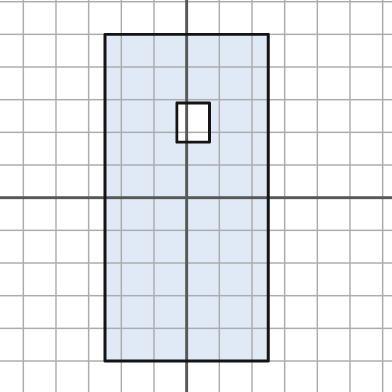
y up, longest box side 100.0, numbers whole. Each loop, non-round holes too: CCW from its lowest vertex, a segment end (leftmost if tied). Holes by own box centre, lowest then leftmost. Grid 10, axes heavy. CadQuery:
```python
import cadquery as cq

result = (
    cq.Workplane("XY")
    .moveTo(-25.0, -50.0)
    .lineTo(25.0, -50.0)
    .lineTo(25.0, 50.0)
    .lineTo(-25.0, 50.0)
    .close()
    .moveTo(-3.0, 17.0)
    .lineTo(7.0, 17.0)
    .lineTo(7.0, 29.0)
    .lineTo(-3.0, 29.0)
    .close()
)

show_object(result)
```